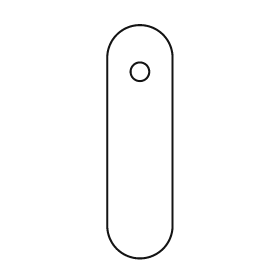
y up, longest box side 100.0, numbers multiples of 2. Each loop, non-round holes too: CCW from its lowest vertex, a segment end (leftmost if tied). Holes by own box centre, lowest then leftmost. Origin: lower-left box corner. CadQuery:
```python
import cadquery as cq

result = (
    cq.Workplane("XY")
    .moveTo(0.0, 14.0)
    .threePointArc((14.0, 0.0), (28.0, 14.0))
    .lineTo(28.0, 86.0)
    .threePointArc((14.0, 100.0), (0.0, 86.0))
    .close()
    .moveTo(14.0, 80.0)
    .circle(4.0)
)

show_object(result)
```